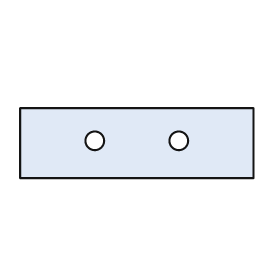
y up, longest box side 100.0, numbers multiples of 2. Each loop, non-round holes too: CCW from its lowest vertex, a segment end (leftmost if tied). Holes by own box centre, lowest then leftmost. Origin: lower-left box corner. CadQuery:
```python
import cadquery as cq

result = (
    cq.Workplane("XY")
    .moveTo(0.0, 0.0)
    .lineTo(100.0, 0.0)
    .lineTo(100.0, 30.0)
    .lineTo(0.0, 30.0)
    .close()
    .moveTo(32.0, 16.0)
    .circle(4.0)
    .moveTo(68.0, 16.0)
    .circle(4.0)
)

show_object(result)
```